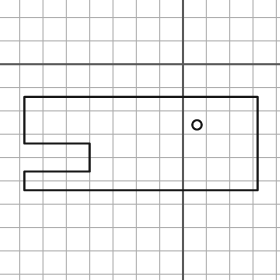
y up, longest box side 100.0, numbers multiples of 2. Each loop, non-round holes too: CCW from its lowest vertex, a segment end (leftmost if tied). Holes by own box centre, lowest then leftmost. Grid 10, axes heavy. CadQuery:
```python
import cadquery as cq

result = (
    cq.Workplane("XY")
    .moveTo(-68.0, -54.0)
    .lineTo(32.0, -54.0)
    .lineTo(32.0, -14.0)
    .lineTo(-68.0, -14.0)
    .lineTo(-68.0, -34.0)
    .lineTo(-40.0, -34.0)
    .lineTo(-40.0, -46.0)
    .lineTo(-68.0, -46.0)
    .close()
    .moveTo(6.0, -26.0)
    .circle(2.0)
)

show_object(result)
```